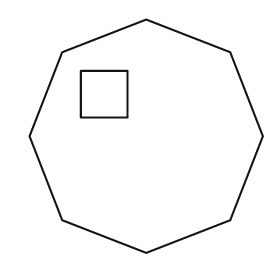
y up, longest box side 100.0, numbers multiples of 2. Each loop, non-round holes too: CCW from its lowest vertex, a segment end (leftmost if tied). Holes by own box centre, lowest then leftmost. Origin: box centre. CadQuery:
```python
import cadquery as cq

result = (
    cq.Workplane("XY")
    .moveTo(0.0, -50.0)
    .lineTo(36.0, -36.0)
    .lineTo(50.0, 0.0)
    .lineTo(36.0, 36.0)
    .lineTo(0.0, 50.0)
    .lineTo(-36.0, 36.0)
    .lineTo(-50.0, 0.0)
    .lineTo(-36.0, -36.0)
    .close()
    .moveTo(-28.0, 8.0)
    .lineTo(-8.0, 8.0)
    .lineTo(-8.0, 28.0)
    .lineTo(-28.0, 28.0)
    .close()
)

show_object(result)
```